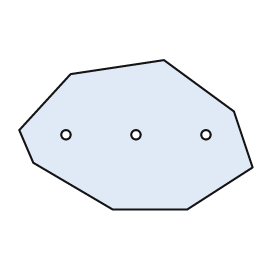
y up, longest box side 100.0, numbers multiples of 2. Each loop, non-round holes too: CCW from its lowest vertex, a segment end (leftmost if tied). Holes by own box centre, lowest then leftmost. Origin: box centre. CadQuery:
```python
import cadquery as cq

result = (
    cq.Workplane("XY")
    .moveTo(-10.0, -32.0)
    .lineTo(22.0, -32.0)
    .lineTo(50.0, -14.0)
    .lineTo(42.0, 10.0)
    .lineTo(12.0, 32.0)
    .lineTo(-28.0, 26.0)
    .lineTo(-50.0, 2.0)
    .lineTo(-44.0, -12.0)
    .close()
    .moveTo(-30.0, 0.0)
    .circle(2.0)
    .moveTo(0.0, 0.0)
    .circle(2.0)
    .moveTo(30.0, 0.0)
    .circle(2.0)
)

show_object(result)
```